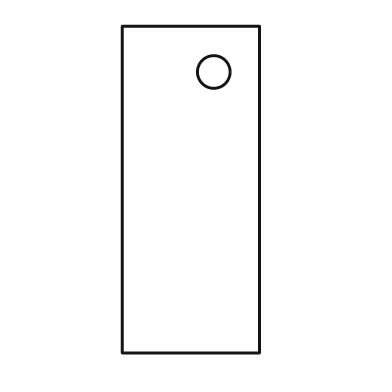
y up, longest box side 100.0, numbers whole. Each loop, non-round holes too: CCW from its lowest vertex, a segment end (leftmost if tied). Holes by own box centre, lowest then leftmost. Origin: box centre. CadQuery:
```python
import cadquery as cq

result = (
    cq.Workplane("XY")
    .moveTo(-21.0, -50.0)
    .lineTo(21.0, -50.0)
    .lineTo(21.0, 50.0)
    .lineTo(-21.0, 50.0)
    .close()
    .moveTo(7.0, 36.0)
    .circle(5.0)
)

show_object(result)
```